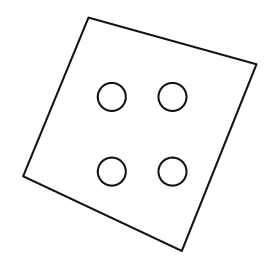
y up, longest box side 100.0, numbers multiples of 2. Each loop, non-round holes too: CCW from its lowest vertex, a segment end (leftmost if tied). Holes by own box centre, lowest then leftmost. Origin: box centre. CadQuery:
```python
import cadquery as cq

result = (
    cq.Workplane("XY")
    .moveTo(18.0, -50.0)
    .lineTo(50.0, 30.0)
    .lineTo(-22.0, 50.0)
    .lineTo(-50.0, -18.0)
    .close()
    .moveTo(-12.0, -16.0)
    .circle(6.0)
    .moveTo(14.0, -16.0)
    .circle(6.0)
    .moveTo(-12.0, 16.0)
    .circle(6.0)
    .moveTo(14.0, 16.0)
    .circle(6.0)
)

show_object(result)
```